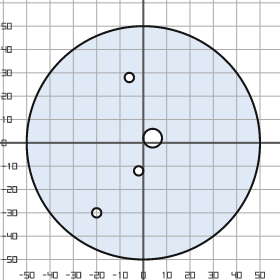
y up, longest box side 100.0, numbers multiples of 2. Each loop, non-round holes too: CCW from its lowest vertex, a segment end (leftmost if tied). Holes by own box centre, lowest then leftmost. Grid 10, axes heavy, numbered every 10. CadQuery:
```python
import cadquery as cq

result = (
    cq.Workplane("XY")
    .moveTo(0.0, 0.0)
    .circle(50.0)
    .moveTo(-20.0, -30.0)
    .circle(2.0)
    .moveTo(-2.0, -12.0)
    .circle(2.0)
    .moveTo(4.0, 2.0)
    .circle(4.0)
    .moveTo(-6.0, 28.0)
    .circle(2.0)
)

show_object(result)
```